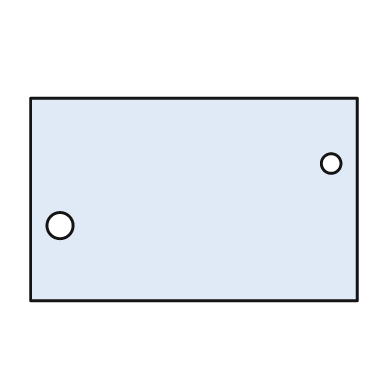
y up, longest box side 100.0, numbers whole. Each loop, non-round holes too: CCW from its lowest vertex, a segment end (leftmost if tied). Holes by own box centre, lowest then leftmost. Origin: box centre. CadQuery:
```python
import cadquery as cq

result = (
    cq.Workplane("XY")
    .moveTo(-50.0, -31.0)
    .lineTo(50.0, -31.0)
    .lineTo(50.0, 31.0)
    .lineTo(-50.0, 31.0)
    .close()
    .moveTo(-41.0, -8.0)
    .circle(4.0)
    .moveTo(42.0, 11.0)
    .circle(3.0)
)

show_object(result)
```